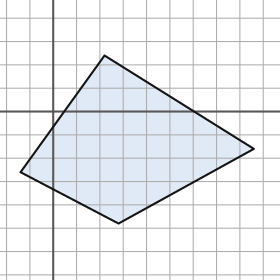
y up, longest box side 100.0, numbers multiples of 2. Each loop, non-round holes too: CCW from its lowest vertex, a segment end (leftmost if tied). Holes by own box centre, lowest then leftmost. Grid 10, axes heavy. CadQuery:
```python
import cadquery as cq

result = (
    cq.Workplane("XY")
    .moveTo(28.0, -48.0)
    .lineTo(86.0, -16.0)
    .lineTo(22.0, 24.0)
    .lineTo(-14.0, -26.0)
    .close()
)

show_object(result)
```